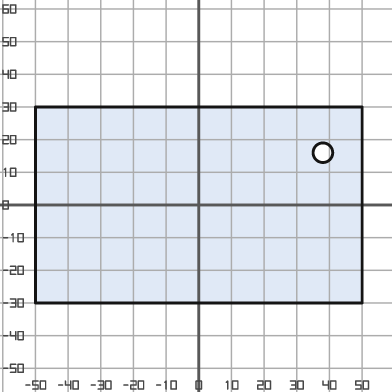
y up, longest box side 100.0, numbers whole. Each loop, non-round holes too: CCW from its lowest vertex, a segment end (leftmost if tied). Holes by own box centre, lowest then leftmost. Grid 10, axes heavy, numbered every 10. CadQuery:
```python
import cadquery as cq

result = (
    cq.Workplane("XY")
    .moveTo(-50.0, -30.0)
    .lineTo(50.0, -30.0)
    .lineTo(50.0, 30.0)
    .lineTo(-50.0, 30.0)
    .close()
    .moveTo(38.0, 16.0)
    .circle(3.0)
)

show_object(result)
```